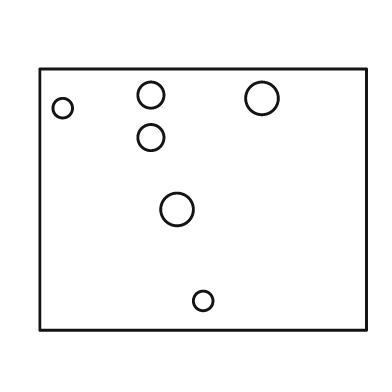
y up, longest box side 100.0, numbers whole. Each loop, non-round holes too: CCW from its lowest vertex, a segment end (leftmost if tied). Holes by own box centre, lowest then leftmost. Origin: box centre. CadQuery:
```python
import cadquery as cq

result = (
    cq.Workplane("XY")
    .moveTo(-50.0, -40.0)
    .lineTo(50.0, -40.0)
    .lineTo(50.0, 40.0)
    .lineTo(-50.0, 40.0)
    .close()
    .moveTo(0.0, -31.0)
    .circle(3.0)
    .moveTo(-8.0, -3.0)
    .circle(5.0)
    .moveTo(-16.0, 19.0)
    .circle(4.0)
    .moveTo(-43.0, 28.0)
    .circle(3.0)
    .moveTo(18.0, 31.0)
    .circle(5.0)
    .moveTo(-16.0, 32.0)
    .circle(4.0)
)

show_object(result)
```